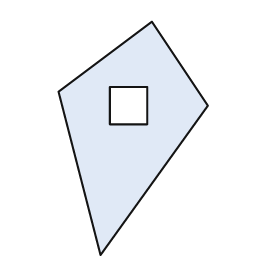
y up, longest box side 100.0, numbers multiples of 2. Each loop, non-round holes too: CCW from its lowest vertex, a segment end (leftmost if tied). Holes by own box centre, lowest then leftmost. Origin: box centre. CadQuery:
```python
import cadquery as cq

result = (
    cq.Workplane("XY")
    .moveTo(-14.0, -50.0)
    .lineTo(32.0, 14.0)
    .lineTo(8.0, 50.0)
    .lineTo(-32.0, 20.0)
    .close()
    .moveTo(-10.0, 6.0)
    .lineTo(6.0, 6.0)
    .lineTo(6.0, 22.0)
    .lineTo(-10.0, 22.0)
    .close()
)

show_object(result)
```